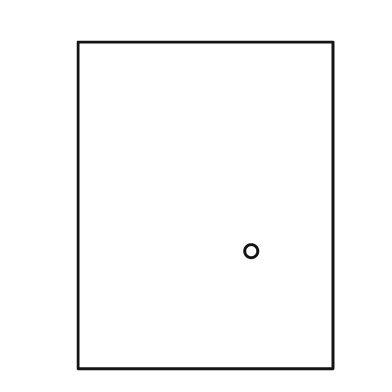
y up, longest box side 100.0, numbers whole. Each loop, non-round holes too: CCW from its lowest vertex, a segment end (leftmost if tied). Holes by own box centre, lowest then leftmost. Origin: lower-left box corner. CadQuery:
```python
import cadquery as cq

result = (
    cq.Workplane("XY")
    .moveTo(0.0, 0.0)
    .lineTo(78.0, 0.0)
    .lineTo(78.0, 100.0)
    .lineTo(0.0, 100.0)
    .close()
    .moveTo(53.0, 36.0)
    .circle(2.0)
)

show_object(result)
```